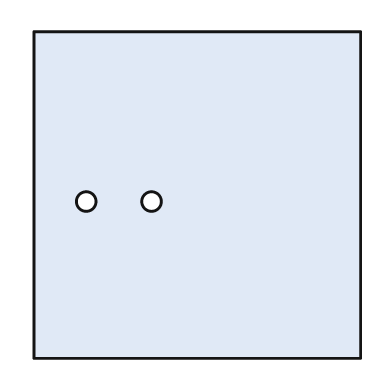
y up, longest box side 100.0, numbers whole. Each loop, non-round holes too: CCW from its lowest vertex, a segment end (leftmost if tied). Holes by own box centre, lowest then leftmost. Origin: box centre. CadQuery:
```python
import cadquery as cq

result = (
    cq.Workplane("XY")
    .moveTo(-50.0, -50.0)
    .lineTo(50.0, -50.0)
    .lineTo(50.0, 50.0)
    .lineTo(-50.0, 50.0)
    .close()
    .moveTo(-34.0, -2.0)
    .circle(3.0)
    .moveTo(-14.0, -2.0)
    .circle(3.0)
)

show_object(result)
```